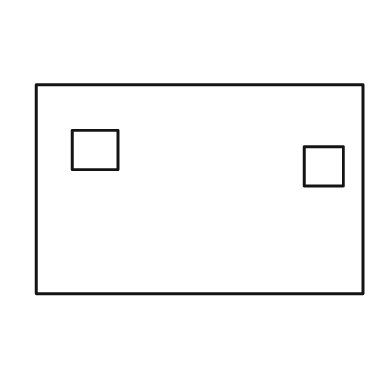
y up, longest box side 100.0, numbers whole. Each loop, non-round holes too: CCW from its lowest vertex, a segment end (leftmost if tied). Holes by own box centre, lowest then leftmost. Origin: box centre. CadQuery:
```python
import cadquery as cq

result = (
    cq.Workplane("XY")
    .moveTo(-50.0, -32.0)
    .lineTo(50.0, -32.0)
    .lineTo(50.0, 32.0)
    .lineTo(-50.0, 32.0)
    .close()
    .moveTo(32.0, 1.0)
    .lineTo(44.0, 1.0)
    .lineTo(44.0, 13.0)
    .lineTo(32.0, 13.0)
    .close()
    .moveTo(-39.0, 6.0)
    .lineTo(-25.0, 6.0)
    .lineTo(-25.0, 18.0)
    .lineTo(-39.0, 18.0)
    .close()
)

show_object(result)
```